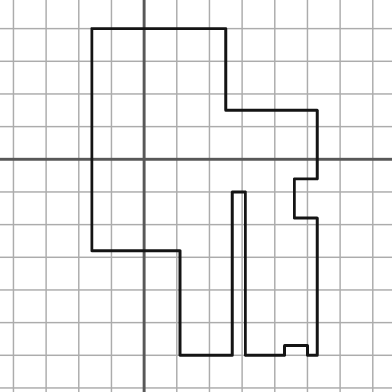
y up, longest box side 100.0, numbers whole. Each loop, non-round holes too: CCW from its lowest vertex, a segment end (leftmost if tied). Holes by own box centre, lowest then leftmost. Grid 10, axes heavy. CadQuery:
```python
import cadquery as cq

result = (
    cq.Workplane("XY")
    .moveTo(11.0, -60.0)
    .lineTo(27.0, -60.0)
    .lineTo(27.0, -10.0)
    .lineTo(31.0, -10.0)
    .lineTo(31.0, -60.0)
    .lineTo(43.0, -60.0)
    .lineTo(43.0, -57.0)
    .lineTo(50.0, -57.0)
    .lineTo(50.0, -60.0)
    .lineTo(53.0, -60.0)
    .lineTo(53.0, -18.0)
    .lineTo(46.0, -18.0)
    .lineTo(46.0, -6.0)
    .lineTo(53.0, -6.0)
    .lineTo(53.0, 15.0)
    .lineTo(25.0, 15.0)
    .lineTo(25.0, 40.0)
    .lineTo(-16.0, 40.0)
    .lineTo(-16.0, -28.0)
    .lineTo(11.0, -28.0)
    .close()
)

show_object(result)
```